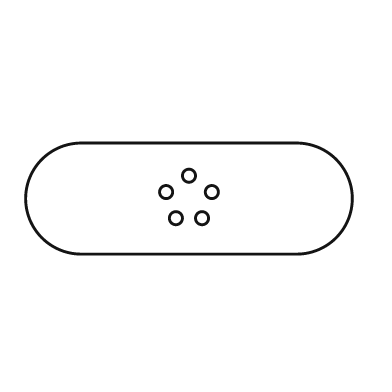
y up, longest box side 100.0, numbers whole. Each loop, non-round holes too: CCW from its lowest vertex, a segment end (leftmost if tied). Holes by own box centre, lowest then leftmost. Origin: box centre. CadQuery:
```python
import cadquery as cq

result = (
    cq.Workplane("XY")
    .moveTo(-33.0, -17.0)
    .lineTo(33.0, -17.0)
    .threePointArc((50.0, 0.0), (33.0, 17.0))
    .lineTo(-33.0, 17.0)
    .threePointArc((-50.0, 0.0), (-33.0, -17.0))
    .close()
    .moveTo(-4.0, -6.0)
    .circle(2.0)
    .moveTo(4.0, -6.0)
    .circle(2.0)
    .moveTo(-7.0, 2.0)
    .circle(2.0)
    .moveTo(7.0, 2.0)
    .circle(2.0)
    .moveTo(0.0, 7.0)
    .circle(2.0)
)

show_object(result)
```